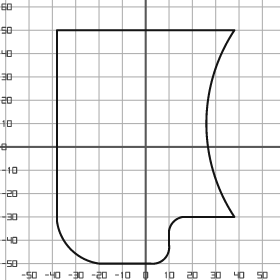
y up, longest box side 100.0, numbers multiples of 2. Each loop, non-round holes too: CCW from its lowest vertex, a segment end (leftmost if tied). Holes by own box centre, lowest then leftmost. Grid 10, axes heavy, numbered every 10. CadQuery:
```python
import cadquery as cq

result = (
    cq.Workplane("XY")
    .moveTo(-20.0, -50.0)
    .lineTo(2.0, -50.0)
    .threePointArc((8.0, -48.0), (10.0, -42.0))
    .lineTo(10.0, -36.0)
    .threePointArc((12.0, -32.0), (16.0, -30.0))
    .lineTo(38.0, -30.0)
    .threePointArc((26.0, 10.0), (38.0, 50.0))
    .lineTo(-38.0, 50.0)
    .lineTo(-38.0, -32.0)
    .threePointArc((-32.0, -44.0), (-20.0, -50.0))
    .close()
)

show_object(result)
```